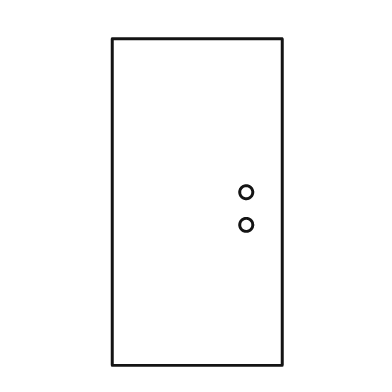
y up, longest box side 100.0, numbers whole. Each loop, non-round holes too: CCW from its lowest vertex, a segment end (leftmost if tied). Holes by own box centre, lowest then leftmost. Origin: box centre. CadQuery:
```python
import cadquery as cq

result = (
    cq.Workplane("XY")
    .moveTo(-26.0, -50.0)
    .lineTo(26.0, -50.0)
    .lineTo(26.0, 50.0)
    .lineTo(-26.0, 50.0)
    .close()
    .moveTo(15.0, -7.0)
    .circle(2.0)
    .moveTo(15.0, 3.0)
    .circle(2.0)
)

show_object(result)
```